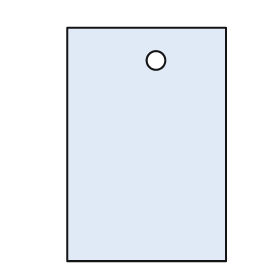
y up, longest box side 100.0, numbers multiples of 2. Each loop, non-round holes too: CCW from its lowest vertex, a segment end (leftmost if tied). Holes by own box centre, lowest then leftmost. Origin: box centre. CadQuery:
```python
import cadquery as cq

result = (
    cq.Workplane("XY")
    .moveTo(-34.0, -50.0)
    .lineTo(34.0, -50.0)
    .lineTo(34.0, 50.0)
    .lineTo(-34.0, 50.0)
    .close()
    .moveTo(4.0, 36.0)
    .circle(4.0)
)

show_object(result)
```